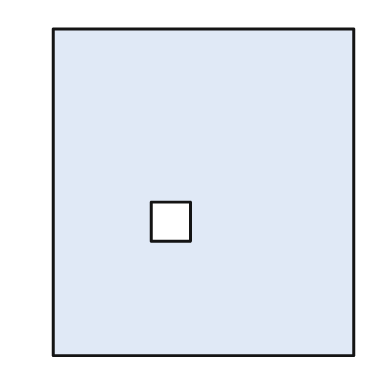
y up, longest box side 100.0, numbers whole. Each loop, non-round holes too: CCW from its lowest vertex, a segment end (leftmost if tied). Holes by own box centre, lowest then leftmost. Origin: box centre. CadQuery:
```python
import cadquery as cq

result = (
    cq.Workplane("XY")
    .moveTo(-46.0, -50.0)
    .lineTo(46.0, -50.0)
    .lineTo(46.0, 50.0)
    .lineTo(-46.0, 50.0)
    .close()
    .moveTo(-16.0, -15.0)
    .lineTo(-4.0, -15.0)
    .lineTo(-4.0, -3.0)
    .lineTo(-16.0, -3.0)
    .close()
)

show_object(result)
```